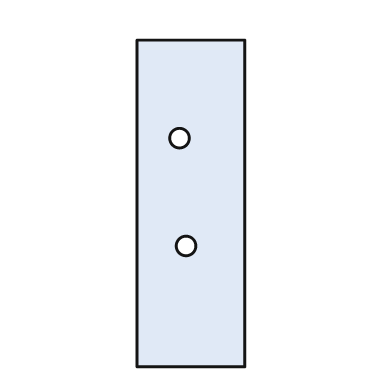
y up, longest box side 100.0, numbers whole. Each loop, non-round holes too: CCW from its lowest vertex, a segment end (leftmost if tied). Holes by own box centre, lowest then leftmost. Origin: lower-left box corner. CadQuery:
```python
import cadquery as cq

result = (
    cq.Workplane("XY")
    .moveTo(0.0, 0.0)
    .lineTo(33.0, 0.0)
    .lineTo(33.0, 100.0)
    .lineTo(0.0, 100.0)
    .close()
    .moveTo(15.0, 37.0)
    .circle(3.0)
    .moveTo(13.0, 70.0)
    .circle(3.0)
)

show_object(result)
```